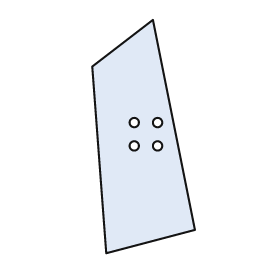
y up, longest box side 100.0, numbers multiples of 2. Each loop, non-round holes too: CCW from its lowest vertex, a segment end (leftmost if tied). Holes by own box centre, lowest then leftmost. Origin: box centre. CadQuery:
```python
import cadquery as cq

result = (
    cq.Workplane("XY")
    .moveTo(-16.0, -50.0)
    .lineTo(22.0, -40.0)
    .lineTo(4.0, 50.0)
    .lineTo(-22.0, 30.0)
    .close()
    .moveTo(-4.0, -4.0)
    .circle(2.0)
    .moveTo(6.0, -4.0)
    .circle(2.0)
    .moveTo(-4.0, 6.0)
    .circle(2.0)
    .moveTo(6.0, 6.0)
    .circle(2.0)
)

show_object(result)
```